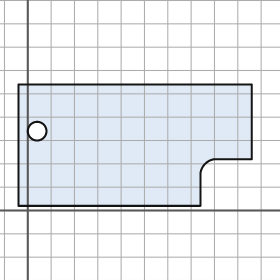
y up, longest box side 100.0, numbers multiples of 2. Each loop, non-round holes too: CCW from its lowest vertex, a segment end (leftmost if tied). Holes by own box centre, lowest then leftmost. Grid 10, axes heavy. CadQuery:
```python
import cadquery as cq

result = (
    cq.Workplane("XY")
    .moveTo(-4.0, 2.0)
    .lineTo(74.0, 2.0)
    .lineTo(74.0, 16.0)
    .threePointArc((76.0, 20.0), (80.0, 22.0))
    .lineTo(96.0, 22.0)
    .lineTo(96.0, 54.0)
    .lineTo(-4.0, 54.0)
    .close()
    .moveTo(4.0, 34.0)
    .circle(4.0)
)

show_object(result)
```